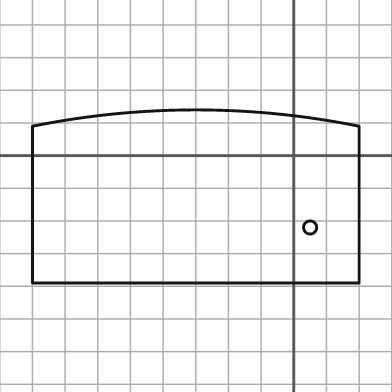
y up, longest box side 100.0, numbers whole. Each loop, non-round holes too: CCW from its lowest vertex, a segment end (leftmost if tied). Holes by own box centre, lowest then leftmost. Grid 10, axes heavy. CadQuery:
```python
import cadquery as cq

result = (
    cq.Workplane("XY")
    .moveTo(-80.0, -39.0)
    .lineTo(20.0, -39.0)
    .lineTo(20.0, 9.0)
    .threePointArc((-30.0, 14.0), (-80.0, 9.0))
    .close()
    .moveTo(5.0, -22.0)
    .circle(2.0)
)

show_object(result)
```